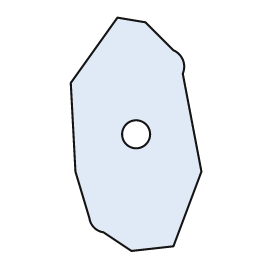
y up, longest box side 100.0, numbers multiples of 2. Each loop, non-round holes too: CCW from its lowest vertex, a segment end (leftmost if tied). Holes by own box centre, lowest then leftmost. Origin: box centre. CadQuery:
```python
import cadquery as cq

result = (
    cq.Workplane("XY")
    .moveTo(-2.0, -50.0)
    .lineTo(16.0, -48.0)
    .lineTo(28.0, -16.0)
    .lineTo(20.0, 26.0)
    .threePointArc((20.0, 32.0), (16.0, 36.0))
    .lineTo(4.0, 48.0)
    .lineTo(-8.0, 50.0)
    .lineTo(-28.0, 22.0)
    .lineTo(-26.0, -16.0)
    .lineTo(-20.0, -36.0)
    .threePointArc((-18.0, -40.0), (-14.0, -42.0))
    .close()
    .moveTo(0.0, 0.0)
    .circle(6.0)
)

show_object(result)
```